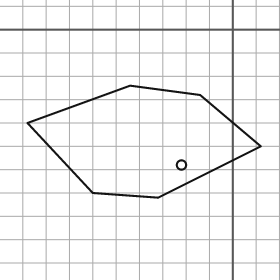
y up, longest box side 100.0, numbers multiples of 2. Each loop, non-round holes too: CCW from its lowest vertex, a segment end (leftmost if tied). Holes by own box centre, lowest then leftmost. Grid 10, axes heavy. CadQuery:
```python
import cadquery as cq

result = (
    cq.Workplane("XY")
    .moveTo(-32.0, -72.0)
    .lineTo(12.0, -50.0)
    .lineTo(-14.0, -28.0)
    .lineTo(-44.0, -24.0)
    .lineTo(-88.0, -40.0)
    .lineTo(-60.0, -70.0)
    .close()
    .moveTo(-22.0, -58.0)
    .circle(2.0)
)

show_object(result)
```